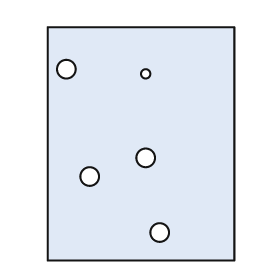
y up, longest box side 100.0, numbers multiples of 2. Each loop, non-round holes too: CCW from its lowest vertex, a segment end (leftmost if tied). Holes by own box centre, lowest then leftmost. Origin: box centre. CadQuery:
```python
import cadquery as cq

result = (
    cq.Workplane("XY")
    .moveTo(-40.0, -50.0)
    .lineTo(40.0, -50.0)
    .lineTo(40.0, 50.0)
    .lineTo(-40.0, 50.0)
    .close()
    .moveTo(8.0, -38.0)
    .circle(4.0)
    .moveTo(-22.0, -14.0)
    .circle(4.0)
    .moveTo(2.0, -6.0)
    .circle(4.0)
    .moveTo(2.0, 30.0)
    .circle(2.0)
    .moveTo(-32.0, 32.0)
    .circle(4.0)
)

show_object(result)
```